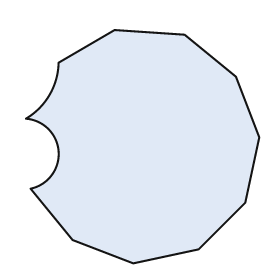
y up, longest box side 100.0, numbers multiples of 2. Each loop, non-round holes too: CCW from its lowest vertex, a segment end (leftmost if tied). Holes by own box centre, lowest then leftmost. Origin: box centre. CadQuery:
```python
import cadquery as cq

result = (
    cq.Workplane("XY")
    .moveTo(-4.0, -50.0)
    .lineTo(24.0, -44.0)
    .lineTo(44.0, -24.0)
    .lineTo(50.0, 4.0)
    .lineTo(40.0, 30.0)
    .lineTo(18.0, 48.0)
    .lineTo(-12.0, 50.0)
    .lineTo(-36.0, 36.0)
    .threePointArc((-40.0, 22.0), (-50.0, 12.0))
    .threePointArc((-36.0, -2.0), (-48.0, -18.0))
    .lineTo(-30.0, -40.0)
    .close()
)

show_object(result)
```